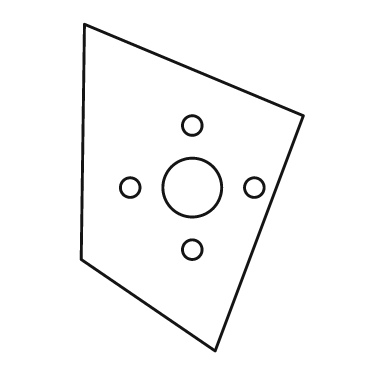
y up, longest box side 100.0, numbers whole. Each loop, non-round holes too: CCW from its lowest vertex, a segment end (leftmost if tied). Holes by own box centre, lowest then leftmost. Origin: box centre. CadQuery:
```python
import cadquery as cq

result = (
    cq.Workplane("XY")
    .moveTo(7.0, -50.0)
    .lineTo(34.0, 22.0)
    .lineTo(-33.0, 50.0)
    .lineTo(-34.0, -22.0)
    .close()
    .moveTo(0.0, -19.0)
    .circle(3.0)
    .moveTo(-19.0, 0.0)
    .circle(3.0)
    .moveTo(0.0, 0.0)
    .circle(9.0)
    .moveTo(19.0, 0.0)
    .circle(3.0)
    .moveTo(0.0, 19.0)
    .circle(3.0)
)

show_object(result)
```